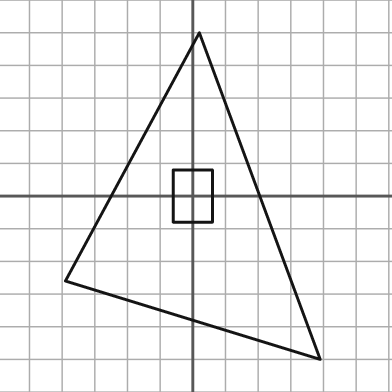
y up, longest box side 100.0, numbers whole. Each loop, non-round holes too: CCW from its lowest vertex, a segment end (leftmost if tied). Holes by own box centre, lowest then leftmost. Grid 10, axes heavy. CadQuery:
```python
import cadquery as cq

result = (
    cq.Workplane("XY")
    .moveTo(39.0, -50.0)
    .lineTo(2.0, 50.0)
    .lineTo(-39.0, -26.0)
    .close()
    .moveTo(-6.0, -8.0)
    .lineTo(6.0, -8.0)
    .lineTo(6.0, 8.0)
    .lineTo(-6.0, 8.0)
    .close()
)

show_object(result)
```